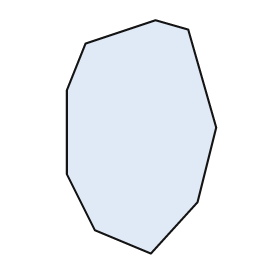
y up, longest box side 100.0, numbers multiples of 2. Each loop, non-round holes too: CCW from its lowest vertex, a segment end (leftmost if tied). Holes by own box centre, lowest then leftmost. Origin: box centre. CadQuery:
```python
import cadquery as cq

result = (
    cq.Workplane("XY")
    .moveTo(4.0, -50.0)
    .lineTo(24.0, -28.0)
    .lineTo(32.0, 4.0)
    .lineTo(20.0, 46.0)
    .lineTo(6.0, 50.0)
    .lineTo(-24.0, 40.0)
    .lineTo(-32.0, 20.0)
    .lineTo(-32.0, -16.0)
    .lineTo(-20.0, -40.0)
    .close()
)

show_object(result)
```